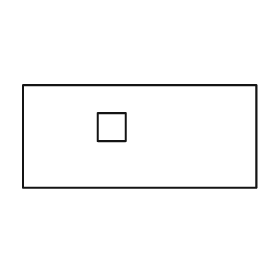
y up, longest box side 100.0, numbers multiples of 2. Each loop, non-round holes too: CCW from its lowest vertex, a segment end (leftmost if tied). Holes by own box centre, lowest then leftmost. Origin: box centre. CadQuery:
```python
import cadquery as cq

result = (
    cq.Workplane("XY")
    .moveTo(-50.0, -22.0)
    .lineTo(50.0, -22.0)
    .lineTo(50.0, 22.0)
    .lineTo(-50.0, 22.0)
    .close()
    .moveTo(-18.0, -2.0)
    .lineTo(-6.0, -2.0)
    .lineTo(-6.0, 10.0)
    .lineTo(-18.0, 10.0)
    .close()
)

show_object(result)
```